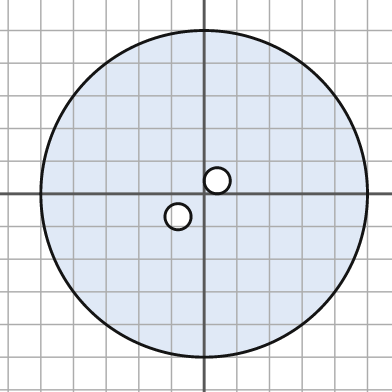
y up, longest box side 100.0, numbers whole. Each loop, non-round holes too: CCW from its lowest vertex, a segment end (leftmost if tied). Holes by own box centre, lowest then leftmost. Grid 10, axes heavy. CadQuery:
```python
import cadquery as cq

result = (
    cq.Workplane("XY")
    .moveTo(0.0, 0.0)
    .circle(50.0)
    .moveTo(-8.0, -7.0)
    .circle(4.0)
    .moveTo(4.0, 4.0)
    .circle(4.0)
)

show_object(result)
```